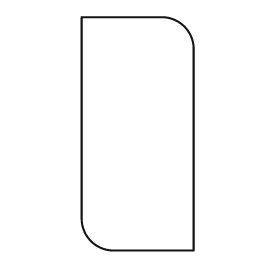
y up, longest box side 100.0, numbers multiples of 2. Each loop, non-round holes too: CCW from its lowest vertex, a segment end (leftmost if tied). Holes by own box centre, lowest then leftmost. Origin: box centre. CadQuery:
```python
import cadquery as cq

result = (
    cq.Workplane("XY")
    .moveTo(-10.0, -50.0)
    .lineTo(24.0, -50.0)
    .lineTo(24.0, 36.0)
    .threePointArc((20.0, 46.0), (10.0, 50.0))
    .lineTo(-24.0, 50.0)
    .lineTo(-24.0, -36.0)
    .threePointArc((-20.0, -46.0), (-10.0, -50.0))
    .close()
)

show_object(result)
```